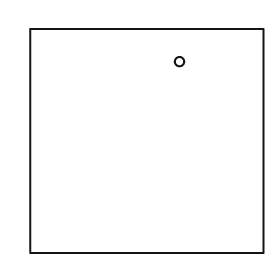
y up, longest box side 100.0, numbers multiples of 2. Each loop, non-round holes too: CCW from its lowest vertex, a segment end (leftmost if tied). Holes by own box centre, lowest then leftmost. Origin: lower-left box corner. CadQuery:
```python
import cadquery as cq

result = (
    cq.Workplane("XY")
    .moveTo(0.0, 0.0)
    .lineTo(100.0, 0.0)
    .lineTo(100.0, 96.0)
    .lineTo(0.0, 96.0)
    .close()
    .moveTo(64.0, 82.0)
    .circle(2.0)
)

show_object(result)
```